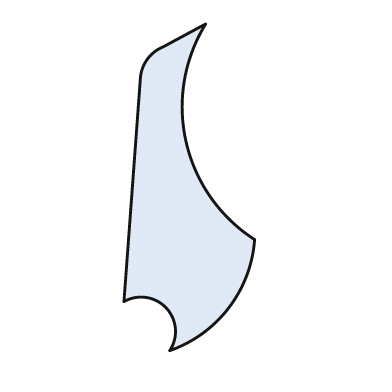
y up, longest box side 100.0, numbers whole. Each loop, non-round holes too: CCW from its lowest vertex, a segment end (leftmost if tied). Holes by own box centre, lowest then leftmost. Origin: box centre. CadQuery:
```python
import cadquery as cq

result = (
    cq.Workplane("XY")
    .moveTo(-6.0, -50.0)
    .threePointArc((12.0, -37.0), (20.0, -16.0))
    .threePointArc((-1.0, 14.0), (5.0, 50.0))
    .lineTo(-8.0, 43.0)
    .threePointArc((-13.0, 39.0), (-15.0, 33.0))
    .lineTo(-20.0, -35.0)
    .threePointArc((-7.0, -37.0), (-6.0, -50.0))
    .close()
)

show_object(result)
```